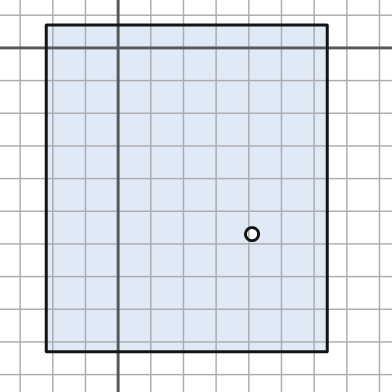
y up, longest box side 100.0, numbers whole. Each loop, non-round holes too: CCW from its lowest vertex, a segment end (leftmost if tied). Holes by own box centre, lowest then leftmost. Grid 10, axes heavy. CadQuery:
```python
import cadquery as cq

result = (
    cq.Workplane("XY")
    .moveTo(-22.0, -93.0)
    .lineTo(64.0, -93.0)
    .lineTo(64.0, 7.0)
    .lineTo(-22.0, 7.0)
    .close()
    .moveTo(41.0, -57.0)
    .circle(2.0)
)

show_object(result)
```